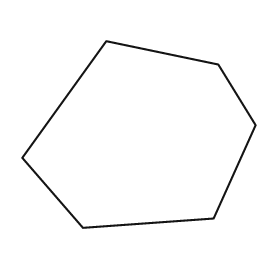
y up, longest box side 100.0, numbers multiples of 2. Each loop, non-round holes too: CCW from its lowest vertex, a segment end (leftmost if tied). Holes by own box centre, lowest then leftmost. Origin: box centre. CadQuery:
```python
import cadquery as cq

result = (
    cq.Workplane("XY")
    .moveTo(-24.0, -40.0)
    .lineTo(32.0, -36.0)
    .lineTo(50.0, 4.0)
    .lineTo(34.0, 30.0)
    .lineTo(-14.0, 40.0)
    .lineTo(-50.0, -10.0)
    .close()
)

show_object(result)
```